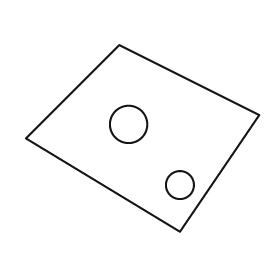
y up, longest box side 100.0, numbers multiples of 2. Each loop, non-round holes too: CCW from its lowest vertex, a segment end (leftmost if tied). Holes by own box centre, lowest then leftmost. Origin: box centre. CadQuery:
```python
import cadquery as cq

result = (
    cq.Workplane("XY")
    .moveTo(16.0, -40.0)
    .lineTo(50.0, 10.0)
    .lineTo(-10.0, 40.0)
    .lineTo(-50.0, 0.0)
    .close()
    .moveTo(16.0, -20.0)
    .circle(6.0)
    .moveTo(-6.0, 6.0)
    .circle(8.0)
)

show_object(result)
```